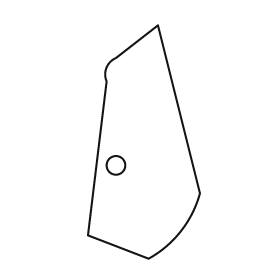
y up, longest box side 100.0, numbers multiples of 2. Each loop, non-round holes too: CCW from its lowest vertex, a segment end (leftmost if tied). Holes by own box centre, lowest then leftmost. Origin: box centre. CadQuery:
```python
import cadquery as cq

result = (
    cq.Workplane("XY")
    .moveTo(2.0, -50.0)
    .threePointArc((16.0, -38.0), (24.0, -22.0))
    .lineTo(6.0, 50.0)
    .lineTo(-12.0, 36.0)
    .threePointArc((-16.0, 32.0), (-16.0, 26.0))
    .lineTo(-24.0, -40.0)
    .close()
    .moveTo(-12.0, -10.0)
    .circle(4.0)
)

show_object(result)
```